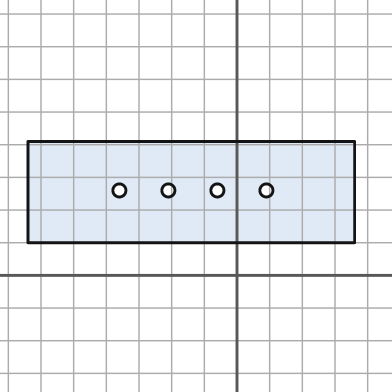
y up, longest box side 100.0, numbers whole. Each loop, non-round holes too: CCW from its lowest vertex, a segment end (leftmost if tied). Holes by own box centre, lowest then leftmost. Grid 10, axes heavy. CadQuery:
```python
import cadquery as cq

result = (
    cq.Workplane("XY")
    .moveTo(-64.0, 10.0)
    .lineTo(36.0, 10.0)
    .lineTo(36.0, 41.0)
    .lineTo(-64.0, 41.0)
    .close()
    .moveTo(-36.0, 26.0)
    .circle(2.0)
    .moveTo(-21.0, 26.0)
    .circle(2.0)
    .moveTo(-6.0, 26.0)
    .circle(2.0)
    .moveTo(9.0, 26.0)
    .circle(2.0)
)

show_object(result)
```